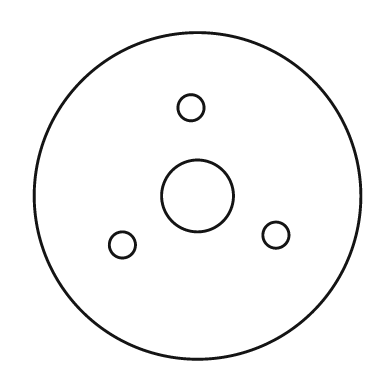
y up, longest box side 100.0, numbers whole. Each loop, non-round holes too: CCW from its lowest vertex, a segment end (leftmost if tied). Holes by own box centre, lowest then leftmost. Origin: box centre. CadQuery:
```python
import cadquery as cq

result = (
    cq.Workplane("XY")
    .moveTo(0.0, 0.0)
    .circle(50.0)
    .moveTo(-23.0, -15.0)
    .circle(4.0)
    .moveTo(24.0, -12.0)
    .circle(4.0)
    .moveTo(0.0, 0.0)
    .circle(11.0)
    .moveTo(-2.0, 27.0)
    .circle(4.0)
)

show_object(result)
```